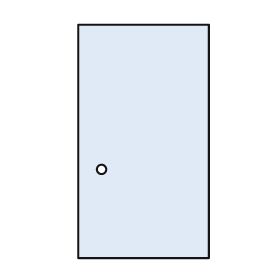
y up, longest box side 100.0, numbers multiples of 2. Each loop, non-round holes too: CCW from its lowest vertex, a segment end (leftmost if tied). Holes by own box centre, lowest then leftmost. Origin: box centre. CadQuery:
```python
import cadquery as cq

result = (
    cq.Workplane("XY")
    .moveTo(-28.0, -50.0)
    .lineTo(28.0, -50.0)
    .lineTo(28.0, 50.0)
    .lineTo(-28.0, 50.0)
    .close()
    .moveTo(-18.0, -12.0)
    .circle(2.0)
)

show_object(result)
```